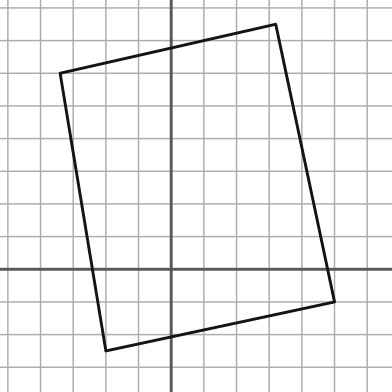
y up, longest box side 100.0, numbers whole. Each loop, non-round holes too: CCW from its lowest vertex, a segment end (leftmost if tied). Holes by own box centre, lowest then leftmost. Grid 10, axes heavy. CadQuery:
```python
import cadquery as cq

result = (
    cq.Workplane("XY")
    .moveTo(-20.0, -25.0)
    .lineTo(50.0, -10.0)
    .lineTo(32.0, 75.0)
    .lineTo(-34.0, 60.0)
    .close()
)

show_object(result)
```